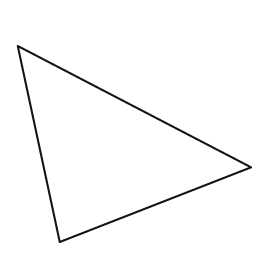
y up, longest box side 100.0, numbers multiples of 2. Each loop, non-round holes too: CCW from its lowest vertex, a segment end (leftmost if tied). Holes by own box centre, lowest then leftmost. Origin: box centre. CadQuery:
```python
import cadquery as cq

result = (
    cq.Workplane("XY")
    .moveTo(-32.0, -42.0)
    .lineTo(50.0, -10.0)
    .lineTo(-50.0, 42.0)
    .close()
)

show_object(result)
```